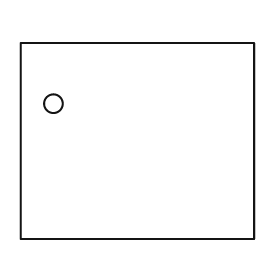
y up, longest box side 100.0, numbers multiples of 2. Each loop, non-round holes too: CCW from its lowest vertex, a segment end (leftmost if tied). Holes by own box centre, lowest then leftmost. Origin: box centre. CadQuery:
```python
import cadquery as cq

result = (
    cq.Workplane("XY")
    .moveTo(-50.0, -42.0)
    .lineTo(50.0, -42.0)
    .lineTo(50.0, 42.0)
    .lineTo(-50.0, 42.0)
    .close()
    .moveTo(-36.0, 16.0)
    .circle(4.0)
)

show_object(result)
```